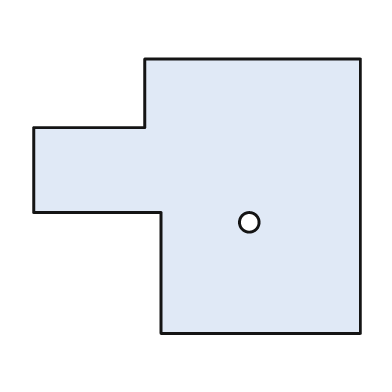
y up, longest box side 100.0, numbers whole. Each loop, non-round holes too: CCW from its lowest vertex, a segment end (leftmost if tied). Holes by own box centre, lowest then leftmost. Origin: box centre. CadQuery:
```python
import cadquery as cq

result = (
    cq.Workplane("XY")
    .moveTo(-11.0, -42.0)
    .lineTo(50.0, -42.0)
    .lineTo(50.0, 42.0)
    .lineTo(-16.0, 42.0)
    .lineTo(-16.0, 21.0)
    .lineTo(-50.0, 21.0)
    .lineTo(-50.0, -5.0)
    .lineTo(-11.0, -5.0)
    .close()
    .moveTo(16.0, -8.0)
    .circle(3.0)
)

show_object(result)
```